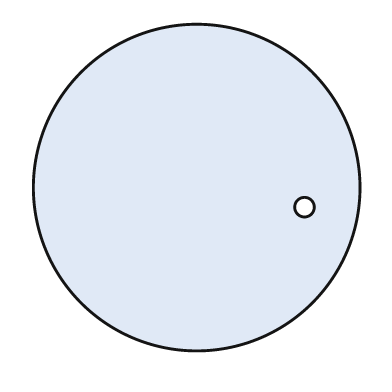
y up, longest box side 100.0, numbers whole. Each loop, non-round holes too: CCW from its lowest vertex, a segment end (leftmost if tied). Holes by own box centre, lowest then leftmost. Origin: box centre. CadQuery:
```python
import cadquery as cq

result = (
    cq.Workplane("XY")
    .moveTo(0.0, 0.0)
    .circle(50.0)
    .moveTo(33.0, -6.0)
    .circle(3.0)
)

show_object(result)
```